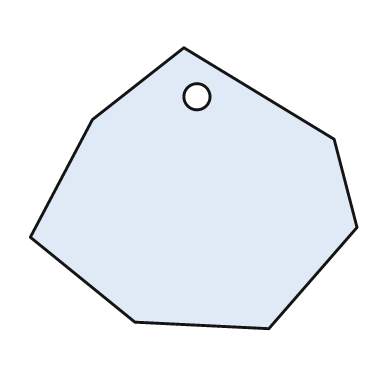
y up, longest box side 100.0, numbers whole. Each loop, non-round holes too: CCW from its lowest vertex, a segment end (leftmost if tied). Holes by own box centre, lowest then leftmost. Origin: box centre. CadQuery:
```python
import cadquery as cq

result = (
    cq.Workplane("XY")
    .moveTo(23.0, -43.0)
    .lineTo(50.0, -12.0)
    .lineTo(43.0, 15.0)
    .lineTo(-3.0, 43.0)
    .lineTo(-31.0, 21.0)
    .lineTo(-50.0, -15.0)
    .lineTo(-18.0, -41.0)
    .close()
    .moveTo(1.0, 28.0)
    .circle(4.0)
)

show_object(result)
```